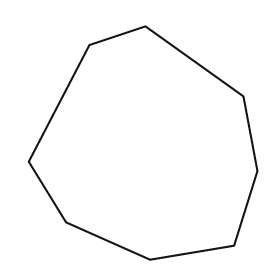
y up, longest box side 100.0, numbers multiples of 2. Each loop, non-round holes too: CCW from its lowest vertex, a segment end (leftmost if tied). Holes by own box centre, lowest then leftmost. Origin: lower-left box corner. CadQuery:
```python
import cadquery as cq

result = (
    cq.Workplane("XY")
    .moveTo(52.0, 0.0)
    .lineTo(88.0, 6.0)
    .lineTo(98.0, 38.0)
    .lineTo(92.0, 70.0)
    .lineTo(50.0, 100.0)
    .lineTo(26.0, 92.0)
    .lineTo(0.0, 42.0)
    .lineTo(16.0, 16.0)
    .close()
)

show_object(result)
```